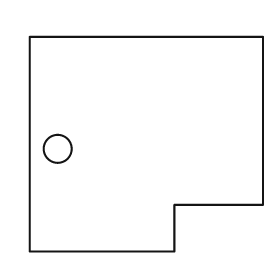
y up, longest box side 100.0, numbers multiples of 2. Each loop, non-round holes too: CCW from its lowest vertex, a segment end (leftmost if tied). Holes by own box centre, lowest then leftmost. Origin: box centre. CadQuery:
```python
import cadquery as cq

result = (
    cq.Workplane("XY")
    .moveTo(-50.0, -46.0)
    .lineTo(12.0, -46.0)
    .lineTo(12.0, -26.0)
    .lineTo(50.0, -26.0)
    .lineTo(50.0, 46.0)
    .lineTo(-50.0, 46.0)
    .close()
    .moveTo(-38.0, -2.0)
    .circle(6.0)
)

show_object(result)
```